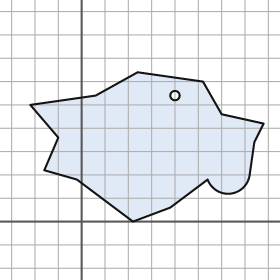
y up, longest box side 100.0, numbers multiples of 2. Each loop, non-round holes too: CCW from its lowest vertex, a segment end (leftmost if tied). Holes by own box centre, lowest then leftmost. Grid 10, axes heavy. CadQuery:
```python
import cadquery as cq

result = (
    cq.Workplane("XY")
    .moveTo(22.0, 0.0)
    .lineTo(38.0, 6.0)
    .lineTo(54.0, 18.0)
    .threePointArc((64.0, 12.0), (72.0, 20.0))
    .lineTo(74.0, 34.0)
    .lineTo(78.0, 42.0)
    .lineTo(60.0, 46.0)
    .lineTo(52.0, 60.0)
    .lineTo(24.0, 64.0)
    .lineTo(6.0, 54.0)
    .lineTo(-22.0, 50.0)
    .lineTo(-10.0, 36.0)
    .lineTo(-16.0, 22.0)
    .lineTo(-2.0, 18.0)
    .close()
    .moveTo(40.0, 54.0)
    .circle(2.0)
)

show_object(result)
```